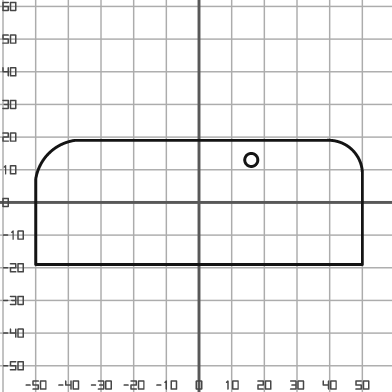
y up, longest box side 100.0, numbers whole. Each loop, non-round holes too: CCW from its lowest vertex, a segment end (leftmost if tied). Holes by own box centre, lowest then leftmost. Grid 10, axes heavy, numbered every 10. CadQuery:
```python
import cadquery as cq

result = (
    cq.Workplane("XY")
    .moveTo(-50.0, -19.0)
    .lineTo(50.0, -19.0)
    .lineTo(50.0, 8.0)
    .threePointArc((47.0, 16.0), (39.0, 19.0))
    .lineTo(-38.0, 19.0)
    .threePointArc((-46.0, 15.0), (-50.0, 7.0))
    .close()
    .moveTo(16.0, 13.0)
    .circle(2.0)
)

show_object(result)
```